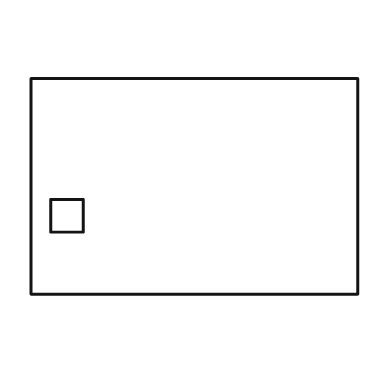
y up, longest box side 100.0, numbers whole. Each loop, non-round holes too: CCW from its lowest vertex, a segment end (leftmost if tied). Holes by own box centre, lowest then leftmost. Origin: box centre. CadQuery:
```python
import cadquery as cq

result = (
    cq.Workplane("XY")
    .moveTo(-50.0, -33.0)
    .lineTo(50.0, -33.0)
    .lineTo(50.0, 33.0)
    .lineTo(-50.0, 33.0)
    .close()
    .moveTo(-44.0, -14.0)
    .lineTo(-34.0, -14.0)
    .lineTo(-34.0, -4.0)
    .lineTo(-44.0, -4.0)
    .close()
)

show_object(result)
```